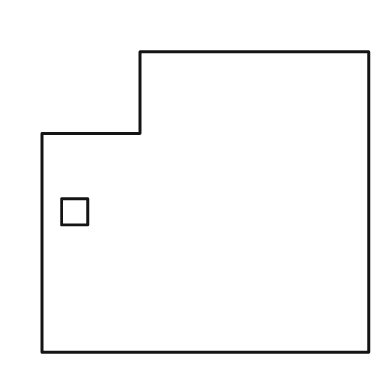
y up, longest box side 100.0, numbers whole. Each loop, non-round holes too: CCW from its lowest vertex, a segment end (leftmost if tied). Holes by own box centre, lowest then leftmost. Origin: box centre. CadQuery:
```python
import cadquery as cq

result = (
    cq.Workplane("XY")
    .moveTo(-50.0, -46.0)
    .lineTo(50.0, -46.0)
    .lineTo(50.0, 46.0)
    .lineTo(-20.0, 46.0)
    .lineTo(-20.0, 21.0)
    .lineTo(-50.0, 21.0)
    .close()
    .moveTo(-44.0, -7.0)
    .lineTo(-36.0, -7.0)
    .lineTo(-36.0, 1.0)
    .lineTo(-44.0, 1.0)
    .close()
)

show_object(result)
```